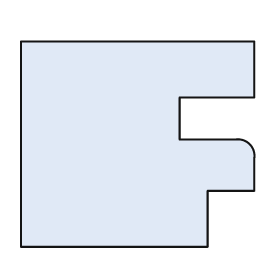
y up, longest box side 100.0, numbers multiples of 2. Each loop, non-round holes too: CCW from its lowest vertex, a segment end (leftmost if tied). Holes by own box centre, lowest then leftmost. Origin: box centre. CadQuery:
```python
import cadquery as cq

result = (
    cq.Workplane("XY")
    .moveTo(-50.0, -44.0)
    .lineTo(30.0, -44.0)
    .lineTo(30.0, -20.0)
    .lineTo(50.0, -20.0)
    .lineTo(50.0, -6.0)
    .threePointArc((48.0, 0.0), (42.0, 2.0))
    .lineTo(18.0, 2.0)
    .lineTo(18.0, 20.0)
    .lineTo(50.0, 20.0)
    .lineTo(50.0, 44.0)
    .lineTo(-50.0, 44.0)
    .close()
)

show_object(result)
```